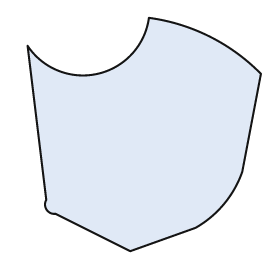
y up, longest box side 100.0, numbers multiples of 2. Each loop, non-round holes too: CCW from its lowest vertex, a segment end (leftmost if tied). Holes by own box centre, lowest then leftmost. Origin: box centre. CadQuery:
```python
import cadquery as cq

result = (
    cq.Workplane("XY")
    .moveTo(-6.0, -50.0)
    .lineTo(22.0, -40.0)
    .threePointArc((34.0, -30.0), (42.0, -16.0))
    .lineTo(50.0, 26.0)
    .threePointArc((28.0, 42.0), (2.0, 50.0))
    .threePointArc((-20.0, 26.0), (-50.0, 38.0))
    .lineTo(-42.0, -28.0)
    .threePointArc((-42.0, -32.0), (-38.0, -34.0))
    .close()
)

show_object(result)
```